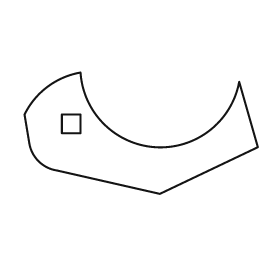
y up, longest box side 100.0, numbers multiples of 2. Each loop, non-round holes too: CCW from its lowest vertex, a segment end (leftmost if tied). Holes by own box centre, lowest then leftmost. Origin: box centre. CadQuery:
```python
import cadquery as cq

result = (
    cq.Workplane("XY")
    .moveTo(8.0, -26.0)
    .lineTo(50.0, -6.0)
    .lineTo(42.0, 22.0)
    .threePointArc((6.0, -6.0), (-26.0, 26.0))
    .threePointArc((-40.0, 20.0), (-50.0, 8.0))
    .lineTo(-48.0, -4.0)
    .threePointArc((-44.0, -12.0), (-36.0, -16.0))
    .close()
    .moveTo(-34.0, 0.0)
    .lineTo(-26.0, 0.0)
    .lineTo(-26.0, 8.0)
    .lineTo(-34.0, 8.0)
    .close()
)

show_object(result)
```